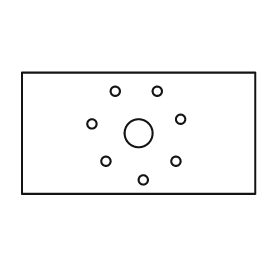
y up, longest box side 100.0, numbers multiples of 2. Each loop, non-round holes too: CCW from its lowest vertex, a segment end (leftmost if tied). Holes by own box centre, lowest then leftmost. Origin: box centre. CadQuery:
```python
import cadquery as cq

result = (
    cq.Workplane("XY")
    .moveTo(-50.0, -26.0)
    .lineTo(50.0, -26.0)
    .lineTo(50.0, 26.0)
    .lineTo(-50.0, 26.0)
    .close()
    .moveTo(2.0, -20.0)
    .circle(2.0)
    .moveTo(-14.0, -12.0)
    .circle(2.0)
    .moveTo(16.0, -12.0)
    .circle(2.0)
    .moveTo(0.0, 0.0)
    .circle(6.0)
    .moveTo(-20.0, 4.0)
    .circle(2.0)
    .moveTo(18.0, 6.0)
    .circle(2.0)
    .moveTo(-10.0, 18.0)
    .circle(2.0)
    .moveTo(8.0, 18.0)
    .circle(2.0)
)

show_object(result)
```